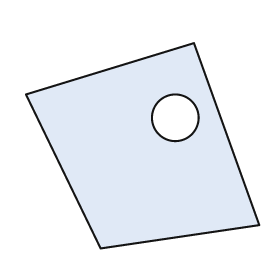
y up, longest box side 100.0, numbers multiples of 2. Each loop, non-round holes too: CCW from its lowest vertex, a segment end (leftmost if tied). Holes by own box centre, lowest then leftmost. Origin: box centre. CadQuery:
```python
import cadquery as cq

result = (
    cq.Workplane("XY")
    .moveTo(-18.0, -44.0)
    .lineTo(50.0, -34.0)
    .lineTo(22.0, 44.0)
    .lineTo(-50.0, 22.0)
    .close()
    .moveTo(14.0, 12.0)
    .circle(10.0)
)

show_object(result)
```